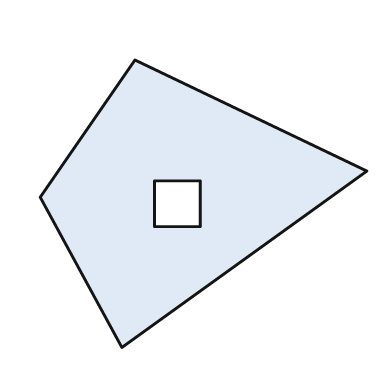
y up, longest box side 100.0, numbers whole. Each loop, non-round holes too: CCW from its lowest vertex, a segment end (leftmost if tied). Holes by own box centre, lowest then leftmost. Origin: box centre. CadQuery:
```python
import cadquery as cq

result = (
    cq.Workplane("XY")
    .moveTo(-25.0, -44.0)
    .lineTo(50.0, 10.0)
    .lineTo(-21.0, 44.0)
    .lineTo(-50.0, 2.0)
    .close()
    .moveTo(-15.0, -7.0)
    .lineTo(-1.0, -7.0)
    .lineTo(-1.0, 7.0)
    .lineTo(-15.0, 7.0)
    .close()
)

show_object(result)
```